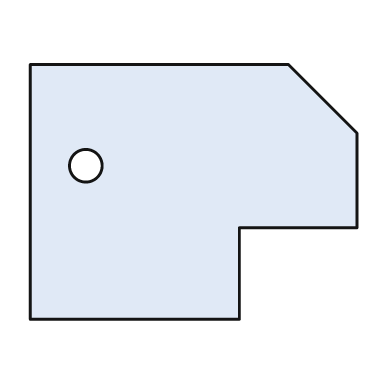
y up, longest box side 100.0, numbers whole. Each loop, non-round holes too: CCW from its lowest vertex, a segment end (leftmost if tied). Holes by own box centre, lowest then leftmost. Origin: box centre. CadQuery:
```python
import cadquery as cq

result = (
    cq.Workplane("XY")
    .moveTo(-50.0, -39.0)
    .lineTo(14.0, -39.0)
    .lineTo(14.0, -11.0)
    .lineTo(50.0, -11.0)
    .lineTo(50.0, 18.0)
    .lineTo(29.0, 39.0)
    .lineTo(-50.0, 39.0)
    .close()
    .moveTo(-33.0, 8.0)
    .circle(5.0)
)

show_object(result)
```